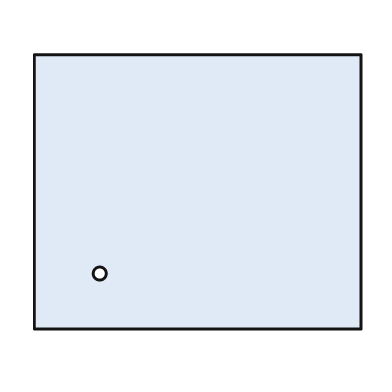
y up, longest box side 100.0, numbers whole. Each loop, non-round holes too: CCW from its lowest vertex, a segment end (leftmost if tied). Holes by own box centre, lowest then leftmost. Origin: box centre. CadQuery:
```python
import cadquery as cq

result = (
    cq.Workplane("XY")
    .moveTo(-50.0, -42.0)
    .lineTo(50.0, -42.0)
    .lineTo(50.0, 42.0)
    .lineTo(-50.0, 42.0)
    .close()
    .moveTo(-30.0, -25.0)
    .circle(2.0)
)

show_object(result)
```